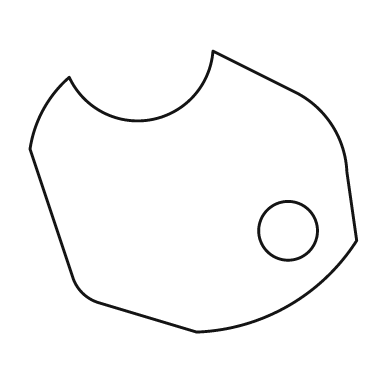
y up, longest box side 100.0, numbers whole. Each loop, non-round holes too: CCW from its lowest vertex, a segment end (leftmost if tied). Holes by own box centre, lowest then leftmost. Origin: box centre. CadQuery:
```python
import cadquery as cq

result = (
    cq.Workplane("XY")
    .moveTo(1.0, -43.0)
    .threePointArc((29.0, -35.0), (50.0, -15.0))
    .lineTo(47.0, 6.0)
    .threePointArc((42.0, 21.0), (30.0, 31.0))
    .lineTo(6.0, 43.0)
    .threePointArc((-13.0, 22.0), (-38.0, 35.0))
    .threePointArc((-46.0, 25.0), (-50.0, 13.0))
    .lineTo(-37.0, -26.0)
    .threePointArc((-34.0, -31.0), (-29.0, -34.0))
    .close()
    .moveTo(29.0, -12.0)
    .circle(9.0)
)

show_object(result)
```